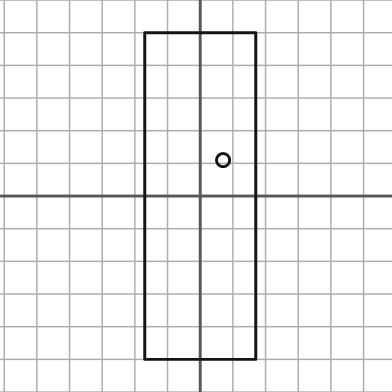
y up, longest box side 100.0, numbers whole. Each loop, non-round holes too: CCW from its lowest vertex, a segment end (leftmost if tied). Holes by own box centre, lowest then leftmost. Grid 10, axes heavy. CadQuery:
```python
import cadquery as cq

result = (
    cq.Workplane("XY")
    .moveTo(-17.0, -50.0)
    .lineTo(17.0, -50.0)
    .lineTo(17.0, 50.0)
    .lineTo(-17.0, 50.0)
    .close()
    .moveTo(7.0, 11.0)
    .circle(2.0)
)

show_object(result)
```